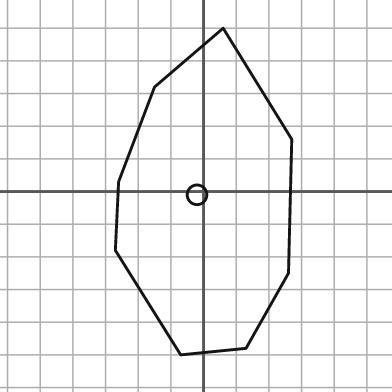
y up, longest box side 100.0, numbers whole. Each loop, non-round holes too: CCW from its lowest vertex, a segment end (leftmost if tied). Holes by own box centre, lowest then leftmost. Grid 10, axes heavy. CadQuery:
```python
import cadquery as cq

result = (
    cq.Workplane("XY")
    .moveTo(-7.0, -50.0)
    .lineTo(13.0, -48.0)
    .lineTo(26.0, -25.0)
    .lineTo(27.0, 16.0)
    .lineTo(6.0, 50.0)
    .lineTo(-15.0, 32.0)
    .lineTo(-26.0, 3.0)
    .lineTo(-27.0, -18.0)
    .close()
    .moveTo(-2.0, -1.0)
    .circle(3.0)
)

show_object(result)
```